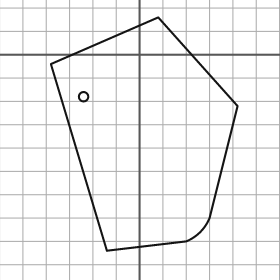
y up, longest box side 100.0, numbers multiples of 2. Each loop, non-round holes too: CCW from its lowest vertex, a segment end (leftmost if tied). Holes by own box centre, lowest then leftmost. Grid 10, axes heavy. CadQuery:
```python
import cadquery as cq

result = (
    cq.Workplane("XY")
    .moveTo(-14.0, -84.0)
    .lineTo(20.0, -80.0)
    .threePointArc((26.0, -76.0), (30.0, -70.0))
    .lineTo(42.0, -22.0)
    .lineTo(8.0, 16.0)
    .lineTo(-38.0, -4.0)
    .close()
    .moveTo(-24.0, -18.0)
    .circle(2.0)
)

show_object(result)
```